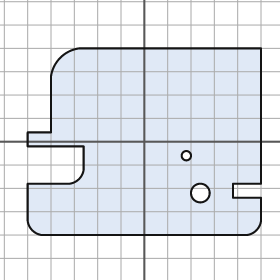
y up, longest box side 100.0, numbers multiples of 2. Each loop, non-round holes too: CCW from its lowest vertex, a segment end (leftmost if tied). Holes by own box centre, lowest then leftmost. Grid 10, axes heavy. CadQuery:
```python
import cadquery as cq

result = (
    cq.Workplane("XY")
    .moveTo(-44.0, -40.0)
    .lineTo(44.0, -40.0)
    .threePointArc((48.0, -38.0), (50.0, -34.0))
    .lineTo(50.0, -24.0)
    .lineTo(38.0, -24.0)
    .lineTo(38.0, -18.0)
    .lineTo(50.0, -18.0)
    .lineTo(50.0, 40.0)
    .lineTo(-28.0, 40.0)
    .threePointArc((-36.0, 36.0), (-40.0, 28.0))
    .lineTo(-40.0, 4.0)
    .lineTo(-50.0, 4.0)
    .lineTo(-50.0, -2.0)
    .lineTo(-26.0, -2.0)
    .lineTo(-26.0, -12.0)
    .threePointArc((-28.0, -16.0), (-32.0, -18.0))
    .lineTo(-50.0, -18.0)
    .lineTo(-50.0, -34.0)
    .threePointArc((-48.0, -38.0), (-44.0, -40.0))
    .close()
    .moveTo(24.0, -22.0)
    .circle(4.0)
    .moveTo(18.0, -6.0)
    .circle(2.0)
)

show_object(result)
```